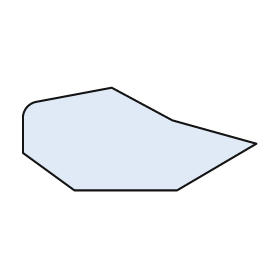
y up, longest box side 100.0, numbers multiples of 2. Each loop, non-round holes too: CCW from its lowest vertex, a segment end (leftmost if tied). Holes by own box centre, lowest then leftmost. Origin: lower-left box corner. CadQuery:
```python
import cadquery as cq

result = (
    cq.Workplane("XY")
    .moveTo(22.0, 0.0)
    .lineTo(66.0, 0.0)
    .lineTo(100.0, 20.0)
    .lineTo(64.0, 30.0)
    .lineTo(38.0, 44.0)
    .lineTo(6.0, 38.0)
    .threePointArc((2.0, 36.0), (0.0, 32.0))
    .lineTo(0.0, 16.0)
    .close()
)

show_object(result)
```